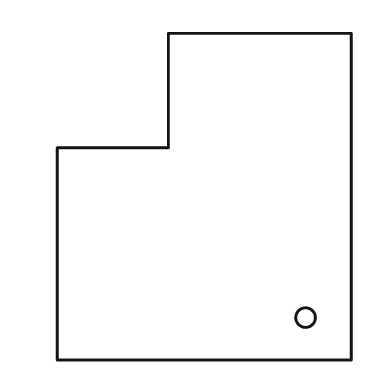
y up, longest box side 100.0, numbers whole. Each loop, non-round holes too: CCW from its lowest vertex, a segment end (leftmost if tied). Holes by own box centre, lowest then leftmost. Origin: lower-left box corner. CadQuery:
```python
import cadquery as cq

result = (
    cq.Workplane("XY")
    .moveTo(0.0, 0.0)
    .lineTo(90.0, 0.0)
    .lineTo(90.0, 100.0)
    .lineTo(34.0, 100.0)
    .lineTo(34.0, 65.0)
    .lineTo(0.0, 65.0)
    .close()
    .moveTo(76.0, 13.0)
    .circle(3.0)
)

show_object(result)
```